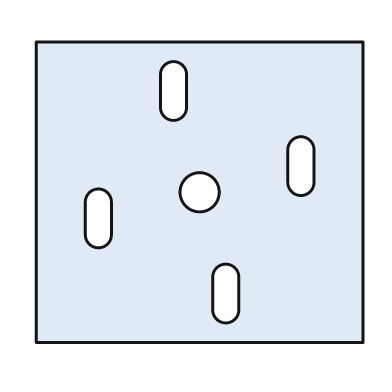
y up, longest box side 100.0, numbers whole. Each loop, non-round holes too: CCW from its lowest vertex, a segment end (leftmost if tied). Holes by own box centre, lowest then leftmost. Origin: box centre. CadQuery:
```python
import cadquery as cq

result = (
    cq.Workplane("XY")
    .moveTo(-50.0, -46.0)
    .lineTo(50.0, -46.0)
    .lineTo(50.0, 46.0)
    .lineTo(-50.0, 46.0)
    .close()
    .moveTo(4.0, -36.0)
    .threePointArc((8.0, -40.0), (12.0, -36.0))
    .lineTo(12.0, -26.0)
    .threePointArc((8.0, -22.0), (4.0, -26.0))
    .close()
    .moveTo(-35.0, -13.0)
    .threePointArc((-31.0, -17.0), (-27.0, -13.0))
    .lineTo(-27.0, -3.0)
    .threePointArc((-31.0, 1.0), (-35.0, -3.0))
    .close()
    .moveTo(0.0, 0.0)
    .circle(6.0)
    .moveTo(27.0, 3.0)
    .threePointArc((31.0, -1.0), (35.0, 3.0))
    .lineTo(35.0, 13.0)
    .threePointArc((31.0, 17.0), (27.0, 13.0))
    .close()
    .moveTo(-12.0, 26.0)
    .threePointArc((-8.0, 22.0), (-4.0, 26.0))
    .lineTo(-4.0, 36.0)
    .threePointArc((-8.0, 40.0), (-12.0, 36.0))
    .close()
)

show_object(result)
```